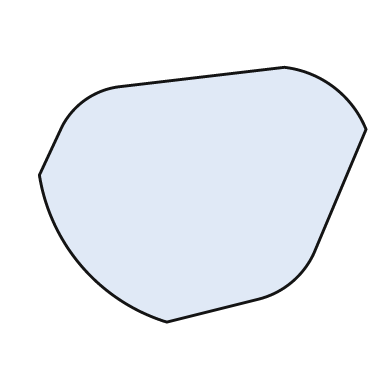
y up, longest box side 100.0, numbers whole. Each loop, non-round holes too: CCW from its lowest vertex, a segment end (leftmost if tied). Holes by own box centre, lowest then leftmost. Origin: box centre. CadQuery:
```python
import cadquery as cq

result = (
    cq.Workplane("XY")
    .moveTo(-11.0, -39.0)
    .lineTo(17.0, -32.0)
    .threePointArc((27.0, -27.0), (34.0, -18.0))
    .lineTo(50.0, 20.0)
    .threePointArc((40.0, 33.0), (25.0, 39.0))
    .lineTo(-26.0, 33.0)
    .threePointArc((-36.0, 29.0), (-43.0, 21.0))
    .lineTo(-50.0, 6.0)
    .threePointArc((-37.0, -22.0), (-11.0, -39.0))
    .close()
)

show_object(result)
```